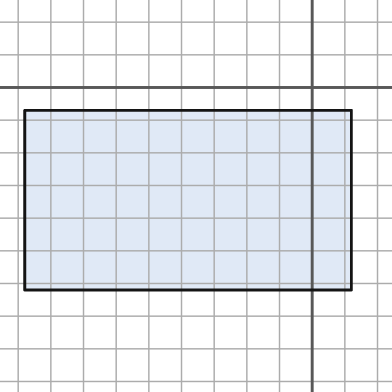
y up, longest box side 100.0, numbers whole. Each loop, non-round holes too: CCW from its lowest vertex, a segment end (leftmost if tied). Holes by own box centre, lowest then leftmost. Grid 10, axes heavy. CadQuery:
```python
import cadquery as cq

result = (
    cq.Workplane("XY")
    .moveTo(-88.0, -62.0)
    .lineTo(12.0, -62.0)
    .lineTo(12.0, -7.0)
    .lineTo(-88.0, -7.0)
    .close()
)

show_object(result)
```